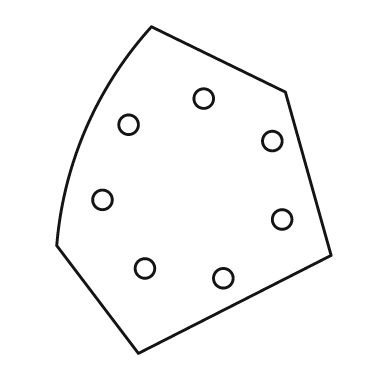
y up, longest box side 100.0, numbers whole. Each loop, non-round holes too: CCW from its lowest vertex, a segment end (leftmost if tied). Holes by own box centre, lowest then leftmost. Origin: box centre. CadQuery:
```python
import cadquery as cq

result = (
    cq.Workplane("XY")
    .moveTo(-17.0, -50.0)
    .lineTo(42.0, -20.0)
    .lineTo(28.0, 30.0)
    .lineTo(-13.0, 50.0)
    .threePointArc((-33.0, 19.0), (-42.0, -17.0))
    .close()
    .moveTo(9.0, -27.0)
    .circle(3.0)
    .moveTo(-15.0, -24.0)
    .circle(3.0)
    .moveTo(27.0, -9.0)
    .circle(3.0)
    .moveTo(-28.0, -3.0)
    .circle(3.0)
    .moveTo(24.0, 15.0)
    .circle(3.0)
    .moveTo(-20.0, 20.0)
    .circle(3.0)
    .moveTo(3.0, 28.0)
    .circle(3.0)
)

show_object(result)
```